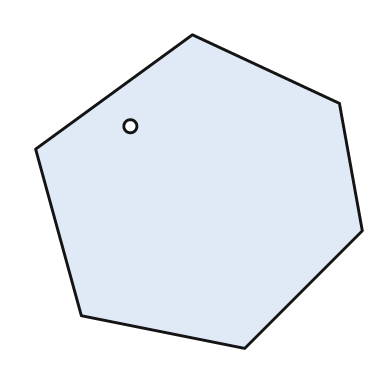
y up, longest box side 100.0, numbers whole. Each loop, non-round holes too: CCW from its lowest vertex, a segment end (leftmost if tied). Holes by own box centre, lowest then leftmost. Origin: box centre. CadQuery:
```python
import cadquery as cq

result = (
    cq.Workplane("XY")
    .moveTo(14.0, -48.0)
    .lineTo(50.0, -12.0)
    .lineTo(43.0, 27.0)
    .lineTo(-2.0, 48.0)
    .lineTo(-50.0, 13.0)
    .lineTo(-36.0, -38.0)
    .close()
    .moveTo(-21.0, 20.0)
    .circle(2.0)
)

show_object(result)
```